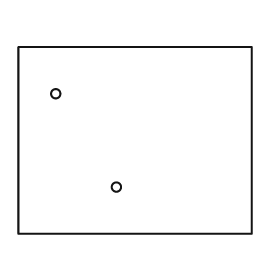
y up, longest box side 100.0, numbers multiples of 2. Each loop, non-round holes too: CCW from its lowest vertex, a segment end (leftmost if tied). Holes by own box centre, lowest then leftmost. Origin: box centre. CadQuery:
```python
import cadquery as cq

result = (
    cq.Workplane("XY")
    .moveTo(-50.0, -40.0)
    .lineTo(50.0, -40.0)
    .lineTo(50.0, 40.0)
    .lineTo(-50.0, 40.0)
    .close()
    .moveTo(-8.0, -20.0)
    .circle(2.0)
    .moveTo(-34.0, 20.0)
    .circle(2.0)
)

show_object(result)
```